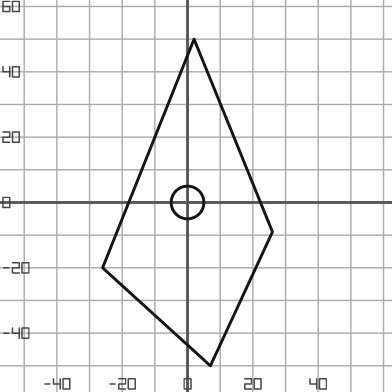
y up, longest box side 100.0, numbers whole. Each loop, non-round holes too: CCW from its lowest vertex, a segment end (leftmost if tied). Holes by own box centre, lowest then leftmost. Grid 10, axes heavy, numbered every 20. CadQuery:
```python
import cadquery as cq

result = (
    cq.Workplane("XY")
    .moveTo(7.0, -50.0)
    .lineTo(26.0, -9.0)
    .lineTo(2.0, 50.0)
    .lineTo(-26.0, -20.0)
    .close()
    .moveTo(0.0, 0.0)
    .circle(5.0)
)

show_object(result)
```